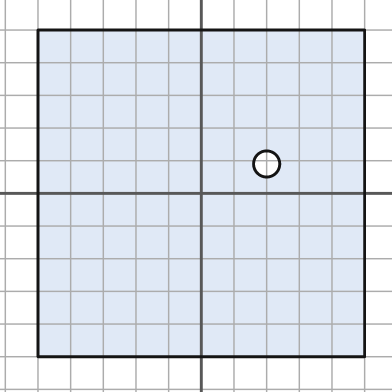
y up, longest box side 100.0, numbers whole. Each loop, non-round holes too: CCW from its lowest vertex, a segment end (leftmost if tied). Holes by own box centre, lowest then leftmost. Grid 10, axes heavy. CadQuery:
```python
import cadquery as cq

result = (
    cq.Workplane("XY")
    .moveTo(-50.0, -50.0)
    .lineTo(50.0, -50.0)
    .lineTo(50.0, 50.0)
    .lineTo(-50.0, 50.0)
    .close()
    .moveTo(20.0, 9.0)
    .circle(4.0)
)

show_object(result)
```